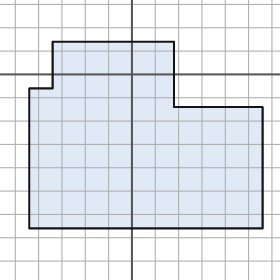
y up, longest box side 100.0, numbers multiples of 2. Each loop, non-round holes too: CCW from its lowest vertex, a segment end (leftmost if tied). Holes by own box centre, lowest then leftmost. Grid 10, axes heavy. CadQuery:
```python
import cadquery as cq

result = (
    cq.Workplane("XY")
    .moveTo(-44.0, -66.0)
    .lineTo(56.0, -66.0)
    .lineTo(56.0, -14.0)
    .lineTo(18.0, -14.0)
    .lineTo(18.0, 14.0)
    .lineTo(-34.0, 14.0)
    .lineTo(-34.0, -6.0)
    .lineTo(-44.0, -6.0)
    .close()
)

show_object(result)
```